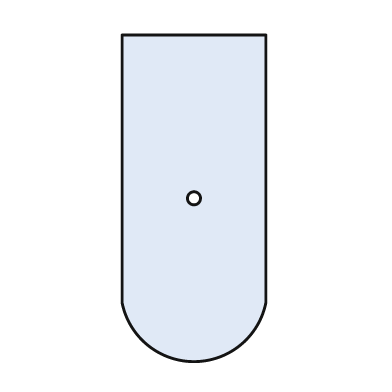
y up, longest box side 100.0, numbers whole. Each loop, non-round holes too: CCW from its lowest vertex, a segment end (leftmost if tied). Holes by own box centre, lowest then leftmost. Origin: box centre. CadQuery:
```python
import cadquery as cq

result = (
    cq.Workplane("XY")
    .moveTo(-22.0, -32.0)
    .threePointArc((0.0, -50.0), (22.0, -32.0))
    .lineTo(22.0, 50.0)
    .lineTo(-22.0, 50.0)
    .close()
    .moveTo(0.0, 0.0)
    .circle(2.0)
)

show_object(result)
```